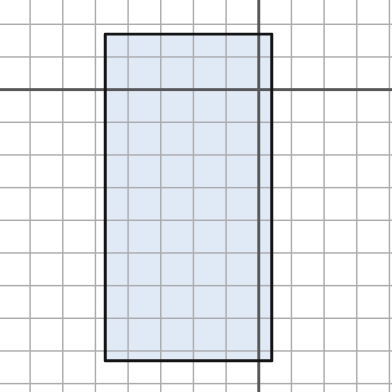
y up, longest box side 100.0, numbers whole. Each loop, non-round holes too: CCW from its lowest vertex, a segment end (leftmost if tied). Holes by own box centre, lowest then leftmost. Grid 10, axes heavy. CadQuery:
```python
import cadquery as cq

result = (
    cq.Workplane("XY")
    .moveTo(-47.0, -83.0)
    .lineTo(4.0, -83.0)
    .lineTo(4.0, 17.0)
    .lineTo(-47.0, 17.0)
    .close()
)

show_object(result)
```